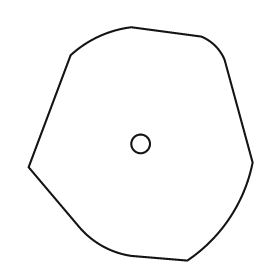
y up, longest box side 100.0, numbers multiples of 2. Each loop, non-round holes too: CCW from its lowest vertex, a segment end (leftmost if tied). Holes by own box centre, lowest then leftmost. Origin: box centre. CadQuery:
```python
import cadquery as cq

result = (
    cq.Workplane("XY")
    .moveTo(20.0, -50.0)
    .threePointArc((38.0, -32.0), (48.0, -8.0))
    .lineTo(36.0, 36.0)
    .threePointArc((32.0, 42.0), (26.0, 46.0))
    .lineTo(-4.0, 50.0)
    .threePointArc((-18.0, 46.0), (-30.0, 38.0))
    .lineTo(-48.0, -10.0)
    .lineTo(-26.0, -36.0)
    .threePointArc((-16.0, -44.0), (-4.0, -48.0))
    .close()
    .moveTo(0.0, 0.0)
    .circle(4.0)
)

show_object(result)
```